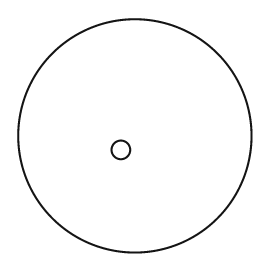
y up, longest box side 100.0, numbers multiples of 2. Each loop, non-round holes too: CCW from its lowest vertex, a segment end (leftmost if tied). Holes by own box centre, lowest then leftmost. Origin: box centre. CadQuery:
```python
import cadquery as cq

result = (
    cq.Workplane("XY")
    .moveTo(0.0, 0.0)
    .circle(50.0)
    .moveTo(-6.0, -6.0)
    .circle(4.0)
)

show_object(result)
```